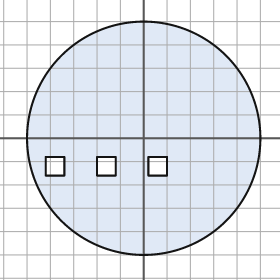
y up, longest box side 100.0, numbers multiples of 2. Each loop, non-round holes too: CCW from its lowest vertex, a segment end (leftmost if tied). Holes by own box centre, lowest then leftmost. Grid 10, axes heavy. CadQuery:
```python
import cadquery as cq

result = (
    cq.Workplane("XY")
    .moveTo(0.0, 0.0)
    .circle(50.0)
    .moveTo(-42.0, -16.0)
    .lineTo(-34.0, -16.0)
    .lineTo(-34.0, -8.0)
    .lineTo(-42.0, -8.0)
    .close()
    .moveTo(-20.0, -16.0)
    .lineTo(-12.0, -16.0)
    .lineTo(-12.0, -8.0)
    .lineTo(-20.0, -8.0)
    .close()
    .moveTo(2.0, -16.0)
    .lineTo(10.0, -16.0)
    .lineTo(10.0, -8.0)
    .lineTo(2.0, -8.0)
    .close()
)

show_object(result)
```